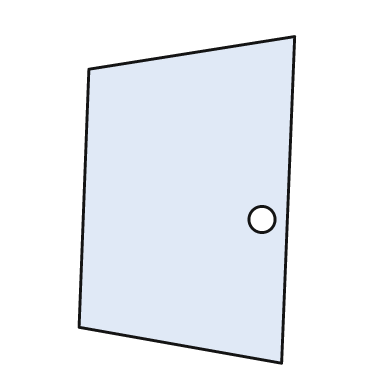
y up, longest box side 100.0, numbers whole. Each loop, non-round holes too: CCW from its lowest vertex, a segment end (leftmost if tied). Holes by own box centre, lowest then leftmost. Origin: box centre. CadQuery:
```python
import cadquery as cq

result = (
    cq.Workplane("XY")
    .moveTo(29.0, -50.0)
    .lineTo(33.0, 50.0)
    .lineTo(-30.0, 40.0)
    .lineTo(-33.0, -39.0)
    .close()
    .moveTo(23.0, -6.0)
    .circle(4.0)
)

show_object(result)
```